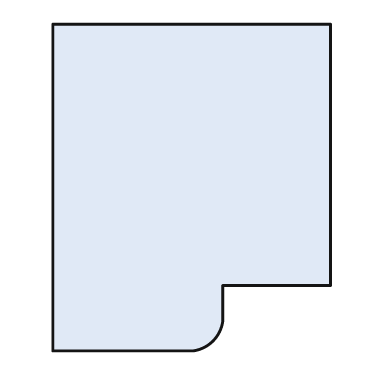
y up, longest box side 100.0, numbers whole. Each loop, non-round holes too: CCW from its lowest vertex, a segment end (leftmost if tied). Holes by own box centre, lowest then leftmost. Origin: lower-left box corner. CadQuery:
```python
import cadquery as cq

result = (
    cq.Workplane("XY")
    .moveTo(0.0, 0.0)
    .lineTo(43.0, 0.0)
    .threePointArc((49.0, 3.0), (52.0, 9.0))
    .lineTo(52.0, 20.0)
    .lineTo(85.0, 20.0)
    .lineTo(85.0, 100.0)
    .lineTo(0.0, 100.0)
    .close()
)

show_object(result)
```